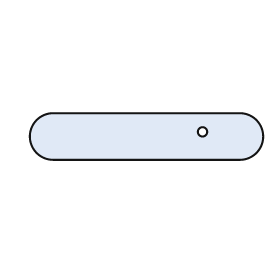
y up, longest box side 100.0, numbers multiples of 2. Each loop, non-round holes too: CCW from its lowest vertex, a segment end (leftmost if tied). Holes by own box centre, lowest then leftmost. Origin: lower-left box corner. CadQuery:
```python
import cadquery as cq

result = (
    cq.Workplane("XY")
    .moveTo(10.0, 0.0)
    .lineTo(90.0, 0.0)
    .threePointArc((100.0, 10.0), (90.0, 20.0))
    .lineTo(10.0, 20.0)
    .threePointArc((0.0, 10.0), (10.0, 0.0))
    .close()
    .moveTo(74.0, 12.0)
    .circle(2.0)
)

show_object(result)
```